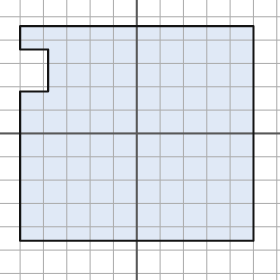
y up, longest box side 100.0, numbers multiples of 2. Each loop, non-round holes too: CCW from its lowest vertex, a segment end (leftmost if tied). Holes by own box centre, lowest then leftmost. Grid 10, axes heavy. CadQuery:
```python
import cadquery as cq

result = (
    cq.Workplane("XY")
    .moveTo(-50.0, -46.0)
    .lineTo(50.0, -46.0)
    .lineTo(50.0, 46.0)
    .lineTo(-50.0, 46.0)
    .lineTo(-50.0, 36.0)
    .lineTo(-38.0, 36.0)
    .lineTo(-38.0, 18.0)
    .lineTo(-50.0, 18.0)
    .close()
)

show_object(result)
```